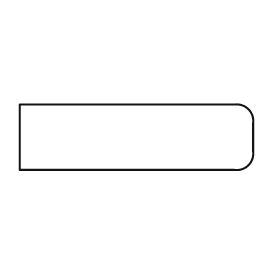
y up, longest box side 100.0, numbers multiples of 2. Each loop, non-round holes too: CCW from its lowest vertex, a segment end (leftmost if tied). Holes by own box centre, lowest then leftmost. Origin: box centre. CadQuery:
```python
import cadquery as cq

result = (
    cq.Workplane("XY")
    .moveTo(-50.0, -14.0)
    .lineTo(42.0, -14.0)
    .threePointArc((48.0, -12.0), (50.0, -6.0))
    .lineTo(50.0, 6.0)
    .threePointArc((48.0, 12.0), (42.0, 14.0))
    .lineTo(-50.0, 14.0)
    .close()
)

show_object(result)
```